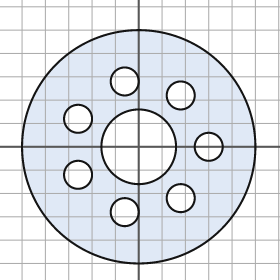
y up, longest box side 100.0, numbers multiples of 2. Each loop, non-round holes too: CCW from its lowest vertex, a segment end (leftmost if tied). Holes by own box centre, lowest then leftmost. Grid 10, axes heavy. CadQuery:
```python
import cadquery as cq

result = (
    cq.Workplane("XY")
    .moveTo(0.0, 0.0)
    .circle(50.0)
    .moveTo(-6.0, -28.0)
    .circle(6.0)
    .moveTo(18.0, -22.0)
    .circle(6.0)
    .moveTo(-26.0, -12.0)
    .circle(6.0)
    .moveTo(0.0, 0.0)
    .circle(16.0)
    .moveTo(30.0, 0.0)
    .circle(6.0)
    .moveTo(-26.0, 12.0)
    .circle(6.0)
    .moveTo(18.0, 22.0)
    .circle(6.0)
    .moveTo(-6.0, 28.0)
    .circle(6.0)
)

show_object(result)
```